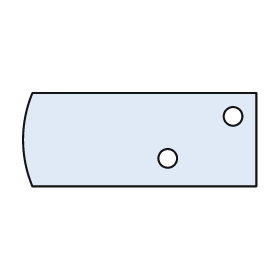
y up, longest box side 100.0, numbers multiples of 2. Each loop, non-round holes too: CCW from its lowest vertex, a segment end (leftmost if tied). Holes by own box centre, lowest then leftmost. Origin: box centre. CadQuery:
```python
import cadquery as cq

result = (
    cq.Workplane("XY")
    .moveTo(-46.0, -20.0)
    .lineTo(50.0, -20.0)
    .lineTo(50.0, 20.0)
    .lineTo(-46.0, 20.0)
    .threePointArc((-50.0, 0.0), (-46.0, -20.0))
    .close()
    .moveTo(12.0, -8.0)
    .circle(4.0)
    .moveTo(40.0, 10.0)
    .circle(4.0)
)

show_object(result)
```